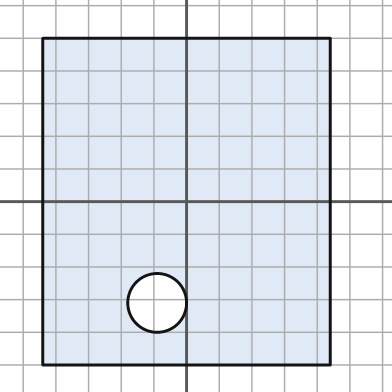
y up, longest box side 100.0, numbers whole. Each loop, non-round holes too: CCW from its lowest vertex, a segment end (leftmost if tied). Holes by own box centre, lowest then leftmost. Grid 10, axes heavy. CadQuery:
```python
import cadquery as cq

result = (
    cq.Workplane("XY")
    .moveTo(-44.0, -50.0)
    .lineTo(44.0, -50.0)
    .lineTo(44.0, 50.0)
    .lineTo(-44.0, 50.0)
    .close()
    .moveTo(-9.0, -31.0)
    .circle(9.0)
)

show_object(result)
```